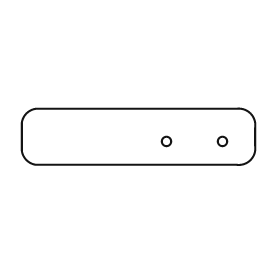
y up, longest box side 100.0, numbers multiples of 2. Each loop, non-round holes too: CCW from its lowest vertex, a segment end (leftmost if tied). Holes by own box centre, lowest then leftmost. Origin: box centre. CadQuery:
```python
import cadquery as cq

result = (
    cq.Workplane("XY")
    .moveTo(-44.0, -12.0)
    .lineTo(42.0, -12.0)
    .threePointArc((48.0, -10.0), (50.0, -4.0))
    .lineTo(50.0, 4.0)
    .threePointArc((48.0, 10.0), (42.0, 12.0))
    .lineTo(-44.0, 12.0)
    .threePointArc((-48.0, 10.0), (-50.0, 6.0))
    .lineTo(-50.0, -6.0)
    .threePointArc((-48.0, -10.0), (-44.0, -12.0))
    .close()
    .moveTo(12.0, -2.0)
    .circle(2.0)
    .moveTo(36.0, -2.0)
    .circle(2.0)
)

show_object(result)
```